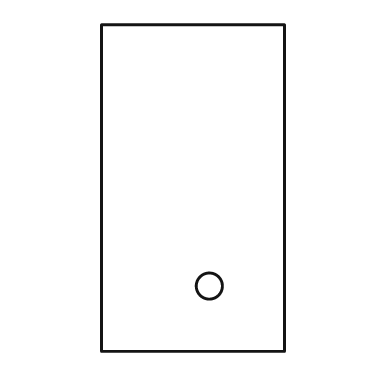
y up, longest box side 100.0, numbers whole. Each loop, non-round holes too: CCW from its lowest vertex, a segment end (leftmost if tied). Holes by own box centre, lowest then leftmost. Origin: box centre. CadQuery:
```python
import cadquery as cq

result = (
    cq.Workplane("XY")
    .moveTo(-28.0, -50.0)
    .lineTo(28.0, -50.0)
    .lineTo(28.0, 50.0)
    .lineTo(-28.0, 50.0)
    .close()
    .moveTo(5.0, -30.0)
    .circle(4.0)
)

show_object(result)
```